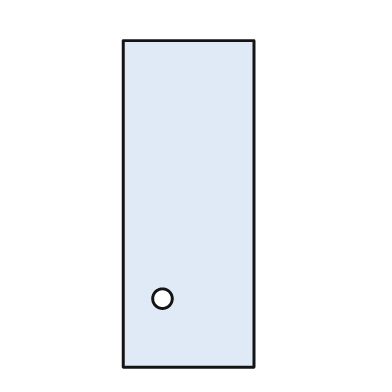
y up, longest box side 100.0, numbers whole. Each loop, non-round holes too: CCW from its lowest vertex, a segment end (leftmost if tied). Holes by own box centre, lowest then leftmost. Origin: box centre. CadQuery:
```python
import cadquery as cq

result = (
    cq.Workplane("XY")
    .moveTo(-20.0, -50.0)
    .lineTo(20.0, -50.0)
    .lineTo(20.0, 50.0)
    .lineTo(-20.0, 50.0)
    .close()
    .moveTo(-8.0, -29.0)
    .circle(3.0)
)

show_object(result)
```